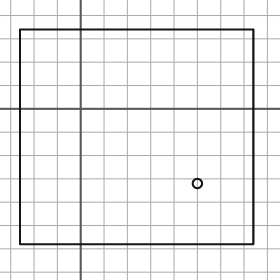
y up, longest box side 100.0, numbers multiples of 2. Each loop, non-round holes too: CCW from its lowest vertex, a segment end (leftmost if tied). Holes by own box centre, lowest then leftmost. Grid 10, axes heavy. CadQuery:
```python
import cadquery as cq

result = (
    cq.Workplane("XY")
    .moveTo(-26.0, -58.0)
    .lineTo(74.0, -58.0)
    .lineTo(74.0, 34.0)
    .lineTo(-26.0, 34.0)
    .close()
    .moveTo(50.0, -32.0)
    .circle(2.0)
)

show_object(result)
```